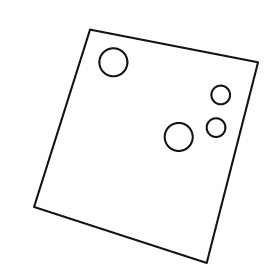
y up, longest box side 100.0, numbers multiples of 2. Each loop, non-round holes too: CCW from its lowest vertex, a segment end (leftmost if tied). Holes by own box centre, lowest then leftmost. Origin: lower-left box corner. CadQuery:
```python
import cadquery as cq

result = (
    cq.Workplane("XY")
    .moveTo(74.0, 0.0)
    .lineTo(96.0, 86.0)
    .lineTo(24.0, 100.0)
    .lineTo(0.0, 24.0)
    .close()
    .moveTo(62.0, 54.0)
    .circle(6.0)
    .moveTo(78.0, 58.0)
    .circle(4.0)
    .moveTo(80.0, 72.0)
    .circle(4.0)
    .moveTo(34.0, 86.0)
    .circle(6.0)
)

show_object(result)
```